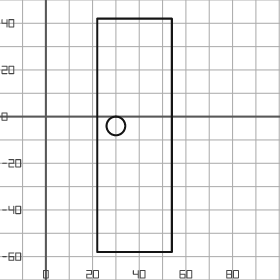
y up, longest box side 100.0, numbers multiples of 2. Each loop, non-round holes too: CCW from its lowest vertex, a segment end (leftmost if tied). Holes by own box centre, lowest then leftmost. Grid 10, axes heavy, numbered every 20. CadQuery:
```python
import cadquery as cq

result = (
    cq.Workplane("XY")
    .moveTo(22.0, -58.0)
    .lineTo(54.0, -58.0)
    .lineTo(54.0, 42.0)
    .lineTo(22.0, 42.0)
    .close()
    .moveTo(30.0, -4.0)
    .circle(4.0)
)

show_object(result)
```